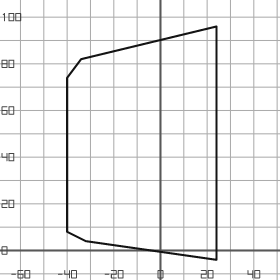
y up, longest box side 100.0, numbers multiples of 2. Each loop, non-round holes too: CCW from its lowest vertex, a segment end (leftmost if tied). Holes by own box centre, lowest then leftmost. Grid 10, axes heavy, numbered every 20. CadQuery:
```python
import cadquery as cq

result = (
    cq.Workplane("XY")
    .moveTo(24.0, -4.0)
    .lineTo(24.0, 96.0)
    .lineTo(-34.0, 82.0)
    .lineTo(-40.0, 74.0)
    .lineTo(-40.0, 8.0)
    .lineTo(-32.0, 4.0)
    .close()
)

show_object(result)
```